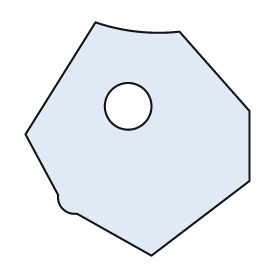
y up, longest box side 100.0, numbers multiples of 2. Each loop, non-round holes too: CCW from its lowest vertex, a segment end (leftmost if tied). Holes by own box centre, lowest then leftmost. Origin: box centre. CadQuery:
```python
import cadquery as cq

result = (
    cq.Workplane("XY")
    .moveTo(6.0, -50.0)
    .lineTo(48.0, -18.0)
    .lineTo(48.0, 12.0)
    .lineTo(18.0, 46.0)
    .threePointArc((0.0, 46.0), (-18.0, 50.0))
    .lineTo(-48.0, 2.0)
    .lineTo(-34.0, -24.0)
    .threePointArc((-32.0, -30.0), (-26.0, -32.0))
    .close()
    .moveTo(-4.0, 14.0)
    .circle(10.0)
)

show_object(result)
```